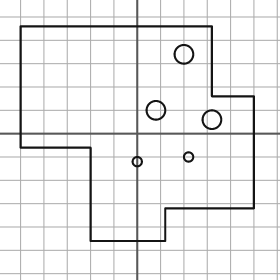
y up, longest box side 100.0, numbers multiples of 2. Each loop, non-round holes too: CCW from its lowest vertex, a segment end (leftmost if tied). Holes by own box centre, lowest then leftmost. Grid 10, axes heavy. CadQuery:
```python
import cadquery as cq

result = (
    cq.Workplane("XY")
    .moveTo(-20.0, -46.0)
    .lineTo(12.0, -46.0)
    .lineTo(12.0, -32.0)
    .lineTo(50.0, -32.0)
    .lineTo(50.0, 16.0)
    .lineTo(32.0, 16.0)
    .lineTo(32.0, 46.0)
    .lineTo(-50.0, 46.0)
    .lineTo(-50.0, -6.0)
    .lineTo(-20.0, -6.0)
    .close()
    .moveTo(0.0, -12.0)
    .circle(2.0)
    .moveTo(22.0, -10.0)
    .circle(2.0)
    .moveTo(32.0, 6.0)
    .circle(4.0)
    .moveTo(8.0, 10.0)
    .circle(4.0)
    .moveTo(20.0, 34.0)
    .circle(4.0)
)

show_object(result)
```